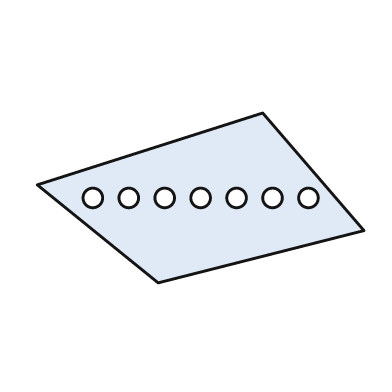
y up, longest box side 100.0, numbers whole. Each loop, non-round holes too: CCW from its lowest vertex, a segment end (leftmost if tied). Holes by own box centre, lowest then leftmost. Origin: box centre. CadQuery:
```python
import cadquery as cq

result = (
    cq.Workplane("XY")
    .moveTo(-13.0, -26.0)
    .lineTo(50.0, -10.0)
    .lineTo(19.0, 26.0)
    .lineTo(-50.0, 4.0)
    .close()
    .moveTo(-33.0, 0.0)
    .circle(3.0)
    .moveTo(-22.0, 0.0)
    .circle(3.0)
    .moveTo(-11.0, 0.0)
    .circle(3.0)
    .moveTo(0.0, 0.0)
    .circle(3.0)
    .moveTo(11.0, 0.0)
    .circle(3.0)
    .moveTo(22.0, 0.0)
    .circle(3.0)
    .moveTo(33.0, 0.0)
    .circle(3.0)
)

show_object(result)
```